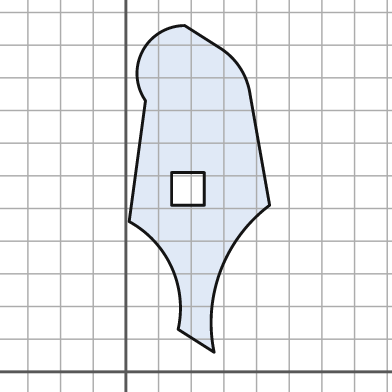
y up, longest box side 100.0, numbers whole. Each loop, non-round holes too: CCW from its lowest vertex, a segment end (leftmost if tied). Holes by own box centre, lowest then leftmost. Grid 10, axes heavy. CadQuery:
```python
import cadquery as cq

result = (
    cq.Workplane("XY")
    .moveTo(27.0, 6.0)
    .threePointArc((29.0, 31.0), (44.0, 51.0))
    .lineTo(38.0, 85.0)
    .threePointArc((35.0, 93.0), (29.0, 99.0))
    .lineTo(18.0, 106.0)
    .threePointArc((5.0, 98.0), (6.0, 83.0))
    .lineTo(1.0, 46.0)
    .threePointArc((14.0, 32.0), (16.0, 13.0))
    .close()
    .moveTo(14.0, 51.0)
    .lineTo(24.0, 51.0)
    .lineTo(24.0, 61.0)
    .lineTo(14.0, 61.0)
    .close()
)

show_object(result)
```